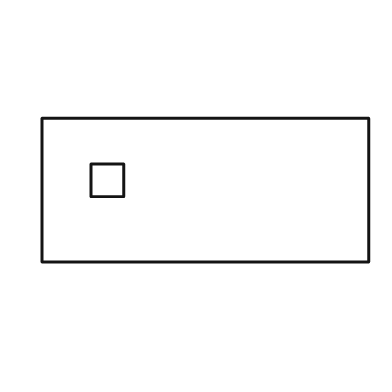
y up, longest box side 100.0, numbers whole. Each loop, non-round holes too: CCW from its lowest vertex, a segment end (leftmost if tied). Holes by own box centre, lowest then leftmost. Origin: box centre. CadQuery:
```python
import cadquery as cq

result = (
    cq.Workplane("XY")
    .moveTo(-50.0, -22.0)
    .lineTo(50.0, -22.0)
    .lineTo(50.0, 22.0)
    .lineTo(-50.0, 22.0)
    .close()
    .moveTo(-35.0, -2.0)
    .lineTo(-25.0, -2.0)
    .lineTo(-25.0, 8.0)
    .lineTo(-35.0, 8.0)
    .close()
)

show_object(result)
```